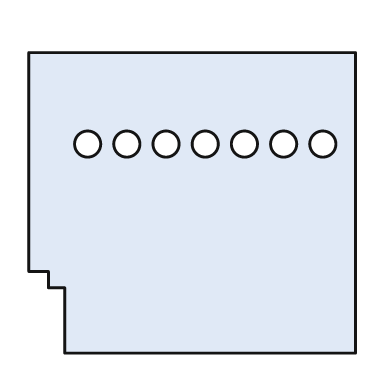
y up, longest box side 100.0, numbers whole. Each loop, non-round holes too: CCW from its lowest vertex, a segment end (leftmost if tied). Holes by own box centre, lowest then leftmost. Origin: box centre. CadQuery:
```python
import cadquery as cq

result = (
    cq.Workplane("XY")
    .moveTo(-39.0, -46.0)
    .lineTo(50.0, -46.0)
    .lineTo(50.0, 46.0)
    .lineTo(-50.0, 46.0)
    .lineTo(-50.0, -21.0)
    .lineTo(-44.0, -21.0)
    .lineTo(-44.0, -26.0)
    .lineTo(-39.0, -26.0)
    .close()
    .moveTo(-32.0, 18.0)
    .circle(4.0)
    .moveTo(-20.0, 18.0)
    .circle(4.0)
    .moveTo(-8.0, 18.0)
    .circle(4.0)
    .moveTo(4.0, 18.0)
    .circle(4.0)
    .moveTo(16.0, 18.0)
    .circle(4.0)
    .moveTo(28.0, 18.0)
    .circle(4.0)
    .moveTo(40.0, 18.0)
    .circle(4.0)
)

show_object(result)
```